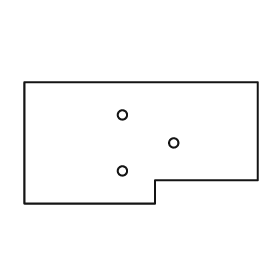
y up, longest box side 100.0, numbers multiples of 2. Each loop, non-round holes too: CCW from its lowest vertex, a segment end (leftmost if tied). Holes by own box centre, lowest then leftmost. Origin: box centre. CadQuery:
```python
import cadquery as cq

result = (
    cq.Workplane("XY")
    .moveTo(-50.0, -26.0)
    .lineTo(6.0, -26.0)
    .lineTo(6.0, -16.0)
    .lineTo(50.0, -16.0)
    .lineTo(50.0, 26.0)
    .lineTo(-50.0, 26.0)
    .close()
    .moveTo(-8.0, -12.0)
    .circle(2.0)
    .moveTo(14.0, 0.0)
    .circle(2.0)
    .moveTo(-8.0, 12.0)
    .circle(2.0)
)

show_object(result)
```